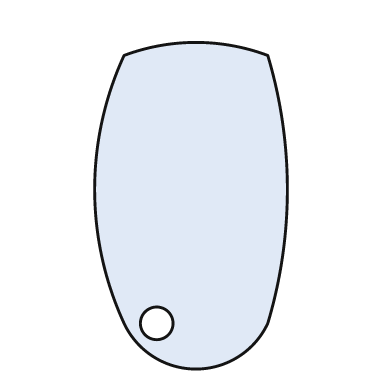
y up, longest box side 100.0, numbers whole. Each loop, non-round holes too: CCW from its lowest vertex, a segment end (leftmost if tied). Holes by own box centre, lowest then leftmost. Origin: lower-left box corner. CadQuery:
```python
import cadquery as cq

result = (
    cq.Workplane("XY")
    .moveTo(9.0, 14.0)
    .threePointArc((31.0, 0.0), (53.0, 14.0))
    .threePointArc((59.0, 55.0), (53.0, 96.0))
    .threePointArc((31.0, 100.0), (9.0, 96.0))
    .threePointArc((0.0, 55.0), (9.0, 14.0))
    .close()
    .moveTo(19.0, 14.0)
    .circle(5.0)
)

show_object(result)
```